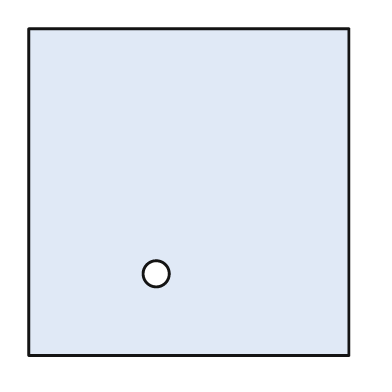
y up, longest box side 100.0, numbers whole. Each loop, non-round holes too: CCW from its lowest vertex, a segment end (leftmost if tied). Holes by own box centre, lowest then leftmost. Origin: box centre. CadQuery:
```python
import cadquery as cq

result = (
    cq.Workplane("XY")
    .moveTo(-49.0, -50.0)
    .lineTo(49.0, -50.0)
    .lineTo(49.0, 50.0)
    .lineTo(-49.0, 50.0)
    .close()
    .moveTo(-10.0, -25.0)
    .circle(4.0)
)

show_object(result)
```